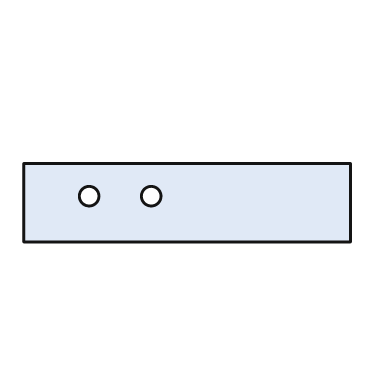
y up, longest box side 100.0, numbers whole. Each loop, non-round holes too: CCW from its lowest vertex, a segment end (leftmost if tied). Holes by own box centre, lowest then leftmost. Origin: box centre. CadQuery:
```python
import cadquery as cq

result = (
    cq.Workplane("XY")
    .moveTo(-50.0, -12.0)
    .lineTo(50.0, -12.0)
    .lineTo(50.0, 12.0)
    .lineTo(-50.0, 12.0)
    .close()
    .moveTo(-30.0, 2.0)
    .circle(3.0)
    .moveTo(-11.0, 2.0)
    .circle(3.0)
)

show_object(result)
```